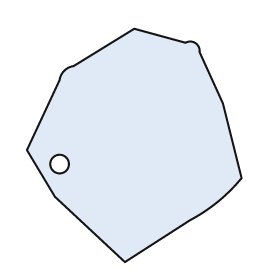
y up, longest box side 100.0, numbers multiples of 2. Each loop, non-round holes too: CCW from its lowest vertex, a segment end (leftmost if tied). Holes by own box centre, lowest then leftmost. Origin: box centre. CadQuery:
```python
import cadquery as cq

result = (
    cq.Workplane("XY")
    .moveTo(-4.0, -50.0)
    .lineTo(24.0, -32.0)
    .threePointArc((36.0, -24.0), (46.0, -14.0))
    .lineTo(38.0, 18.0)
    .lineTo(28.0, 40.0)
    .threePointArc((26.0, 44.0), (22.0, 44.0))
    .lineTo(0.0, 50.0)
    .lineTo(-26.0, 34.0)
    .threePointArc((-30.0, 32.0), (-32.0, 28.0))
    .lineTo(-46.0, -2.0)
    .lineTo(-34.0, -22.0)
    .close()
    .moveTo(-32.0, -8.0)
    .circle(4.0)
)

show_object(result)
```